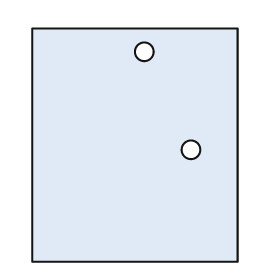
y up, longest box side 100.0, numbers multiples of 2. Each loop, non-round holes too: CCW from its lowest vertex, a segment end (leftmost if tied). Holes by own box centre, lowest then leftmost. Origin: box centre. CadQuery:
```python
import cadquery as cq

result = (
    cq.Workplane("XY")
    .moveTo(-44.0, -50.0)
    .lineTo(44.0, -50.0)
    .lineTo(44.0, 50.0)
    .lineTo(-44.0, 50.0)
    .close()
    .moveTo(24.0, -2.0)
    .circle(4.0)
    .moveTo(4.0, 40.0)
    .circle(4.0)
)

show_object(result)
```